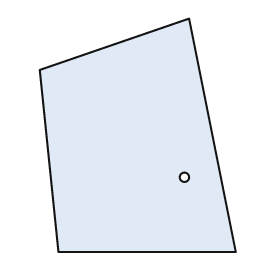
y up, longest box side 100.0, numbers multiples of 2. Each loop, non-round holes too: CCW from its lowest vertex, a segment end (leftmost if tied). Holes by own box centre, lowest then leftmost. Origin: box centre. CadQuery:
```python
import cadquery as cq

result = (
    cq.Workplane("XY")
    .moveTo(-34.0, -50.0)
    .lineTo(42.0, -50.0)
    .lineTo(22.0, 50.0)
    .lineTo(-42.0, 28.0)
    .close()
    .moveTo(20.0, -18.0)
    .circle(2.0)
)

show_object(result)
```